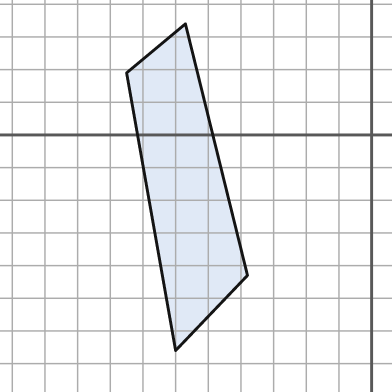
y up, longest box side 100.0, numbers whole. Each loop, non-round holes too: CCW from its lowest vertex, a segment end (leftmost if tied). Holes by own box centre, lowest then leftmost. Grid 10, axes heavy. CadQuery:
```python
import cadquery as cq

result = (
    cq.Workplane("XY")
    .moveTo(-60.0, -66.0)
    .lineTo(-38.0, -43.0)
    .lineTo(-57.0, 34.0)
    .lineTo(-75.0, 19.0)
    .close()
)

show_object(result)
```